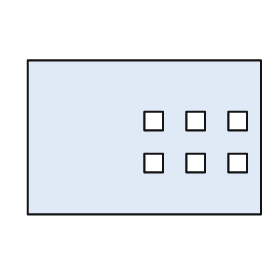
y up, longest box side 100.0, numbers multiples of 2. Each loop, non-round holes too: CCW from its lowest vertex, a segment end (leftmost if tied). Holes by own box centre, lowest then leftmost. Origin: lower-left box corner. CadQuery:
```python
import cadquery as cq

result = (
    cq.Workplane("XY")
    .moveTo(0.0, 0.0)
    .lineTo(100.0, 0.0)
    .lineTo(100.0, 66.0)
    .lineTo(0.0, 66.0)
    .close()
    .moveTo(50.0, 18.0)
    .lineTo(58.0, 18.0)
    .lineTo(58.0, 26.0)
    .lineTo(50.0, 26.0)
    .close()
    .moveTo(68.0, 18.0)
    .lineTo(76.0, 18.0)
    .lineTo(76.0, 26.0)
    .lineTo(68.0, 26.0)
    .close()
    .moveTo(86.0, 18.0)
    .lineTo(94.0, 18.0)
    .lineTo(94.0, 26.0)
    .lineTo(86.0, 26.0)
    .close()
    .moveTo(50.0, 36.0)
    .lineTo(58.0, 36.0)
    .lineTo(58.0, 44.0)
    .lineTo(50.0, 44.0)
    .close()
    .moveTo(68.0, 36.0)
    .lineTo(76.0, 36.0)
    .lineTo(76.0, 44.0)
    .lineTo(68.0, 44.0)
    .close()
    .moveTo(86.0, 36.0)
    .lineTo(94.0, 36.0)
    .lineTo(94.0, 44.0)
    .lineTo(86.0, 44.0)
    .close()
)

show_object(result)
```